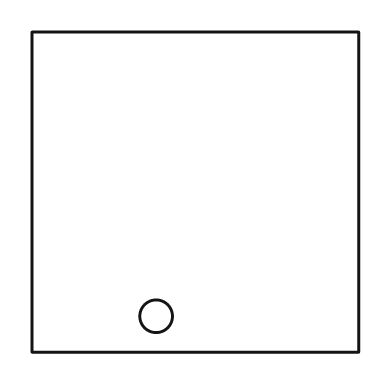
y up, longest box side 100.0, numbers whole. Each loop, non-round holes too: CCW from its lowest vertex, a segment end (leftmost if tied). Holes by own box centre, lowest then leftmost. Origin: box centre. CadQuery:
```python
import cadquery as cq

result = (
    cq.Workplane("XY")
    .moveTo(-50.0, -49.0)
    .lineTo(50.0, -49.0)
    .lineTo(50.0, 49.0)
    .lineTo(-50.0, 49.0)
    .close()
    .moveTo(-12.0, -38.0)
    .circle(5.0)
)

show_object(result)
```